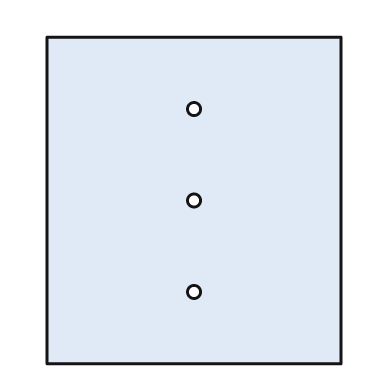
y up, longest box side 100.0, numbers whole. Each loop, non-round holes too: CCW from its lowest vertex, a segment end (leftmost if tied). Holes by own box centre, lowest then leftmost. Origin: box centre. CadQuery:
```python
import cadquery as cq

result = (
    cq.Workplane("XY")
    .moveTo(-45.0, -50.0)
    .lineTo(45.0, -50.0)
    .lineTo(45.0, 50.0)
    .lineTo(-45.0, 50.0)
    .close()
    .moveTo(0.0, -28.0)
    .circle(2.0)
    .moveTo(0.0, 0.0)
    .circle(2.0)
    .moveTo(0.0, 28.0)
    .circle(2.0)
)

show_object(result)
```